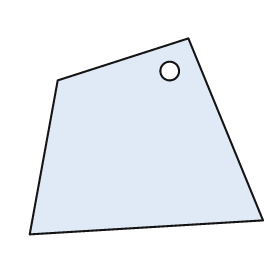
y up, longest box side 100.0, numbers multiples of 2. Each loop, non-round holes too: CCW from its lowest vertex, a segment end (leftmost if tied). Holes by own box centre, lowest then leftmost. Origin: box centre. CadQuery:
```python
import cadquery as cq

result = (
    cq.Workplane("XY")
    .moveTo(-50.0, -42.0)
    .lineTo(50.0, -36.0)
    .lineTo(18.0, 42.0)
    .lineTo(-38.0, 24.0)
    .close()
    .moveTo(10.0, 28.0)
    .circle(4.0)
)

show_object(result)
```